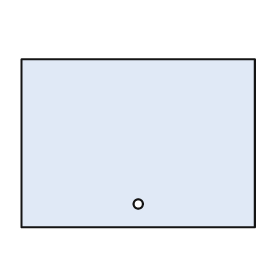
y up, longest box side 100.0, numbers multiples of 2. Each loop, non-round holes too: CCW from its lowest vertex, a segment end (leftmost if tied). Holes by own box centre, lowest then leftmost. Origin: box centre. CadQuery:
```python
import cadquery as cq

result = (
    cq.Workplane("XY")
    .moveTo(-50.0, -36.0)
    .lineTo(50.0, -36.0)
    .lineTo(50.0, 36.0)
    .lineTo(-50.0, 36.0)
    .close()
    .moveTo(0.0, -26.0)
    .circle(2.0)
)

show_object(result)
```